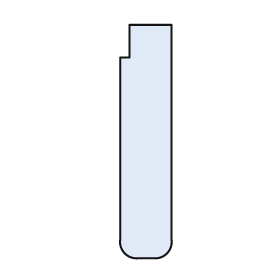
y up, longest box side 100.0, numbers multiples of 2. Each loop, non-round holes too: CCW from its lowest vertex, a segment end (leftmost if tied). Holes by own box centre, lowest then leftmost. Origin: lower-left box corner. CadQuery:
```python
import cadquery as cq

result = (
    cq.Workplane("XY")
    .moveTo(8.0, 0.0)
    .lineTo(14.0, 0.0)
    .threePointArc((20.0, 2.0), (22.0, 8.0))
    .lineTo(22.0, 100.0)
    .lineTo(4.0, 100.0)
    .lineTo(4.0, 86.0)
    .lineTo(0.0, 86.0)
    .lineTo(0.0, 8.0)
    .threePointArc((2.0, 2.0), (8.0, 0.0))
    .close()
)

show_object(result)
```